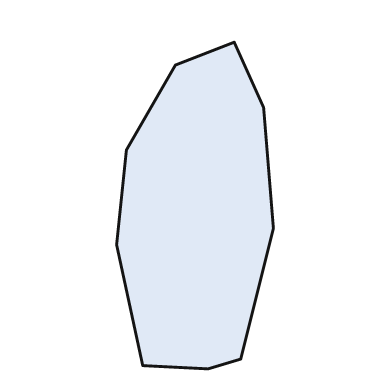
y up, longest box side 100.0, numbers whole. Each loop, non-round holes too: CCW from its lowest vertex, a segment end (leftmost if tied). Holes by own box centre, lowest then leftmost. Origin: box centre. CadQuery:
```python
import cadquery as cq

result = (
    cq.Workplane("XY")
    .moveTo(4.0, -50.0)
    .lineTo(14.0, -47.0)
    .lineTo(24.0, -7.0)
    .lineTo(21.0, 30.0)
    .lineTo(12.0, 50.0)
    .lineTo(-6.0, 43.0)
    .lineTo(-21.0, 17.0)
    .lineTo(-24.0, -12.0)
    .lineTo(-16.0, -49.0)
    .close()
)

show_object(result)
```